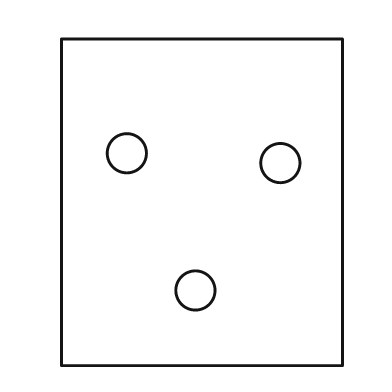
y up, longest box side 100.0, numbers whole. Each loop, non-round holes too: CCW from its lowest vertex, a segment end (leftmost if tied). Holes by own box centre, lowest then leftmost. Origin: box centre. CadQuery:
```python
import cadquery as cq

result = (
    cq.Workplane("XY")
    .moveTo(-43.0, -50.0)
    .lineTo(43.0, -50.0)
    .lineTo(43.0, 50.0)
    .lineTo(-43.0, 50.0)
    .close()
    .moveTo(-2.0, -27.0)
    .circle(6.0)
    .moveTo(24.0, 12.0)
    .circle(6.0)
    .moveTo(-23.0, 15.0)
    .circle(6.0)
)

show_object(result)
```